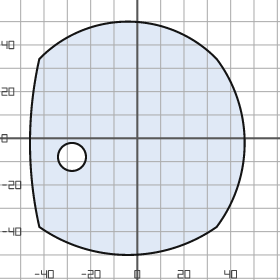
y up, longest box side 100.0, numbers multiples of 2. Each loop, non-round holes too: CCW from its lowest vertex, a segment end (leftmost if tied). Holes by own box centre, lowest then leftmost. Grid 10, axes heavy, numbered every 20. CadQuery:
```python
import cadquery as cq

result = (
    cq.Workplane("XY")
    .moveTo(-42.0, -38.0)
    .threePointArc((-4.0, -50.0), (34.0, -38.0))
    .threePointArc((46.0, -2.0), (34.0, 34.0))
    .threePointArc((-4.0, 50.0), (-42.0, 34.0))
    .threePointArc((-46.0, -2.0), (-42.0, -38.0))
    .close()
    .moveTo(-28.0, -8.0)
    .circle(6.0)
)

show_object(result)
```